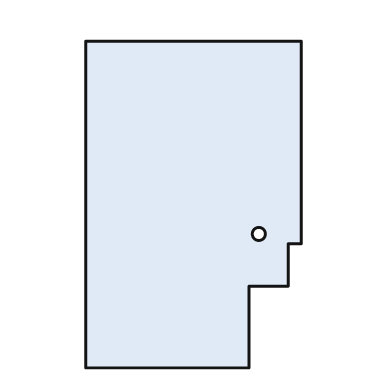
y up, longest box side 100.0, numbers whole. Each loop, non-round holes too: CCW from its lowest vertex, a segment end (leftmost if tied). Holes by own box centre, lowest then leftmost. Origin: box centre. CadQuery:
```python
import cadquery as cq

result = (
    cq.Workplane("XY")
    .moveTo(-33.0, -50.0)
    .lineTo(17.0, -50.0)
    .lineTo(17.0, -25.0)
    .lineTo(29.0, -25.0)
    .lineTo(29.0, -12.0)
    .lineTo(33.0, -12.0)
    .lineTo(33.0, 50.0)
    .lineTo(-33.0, 50.0)
    .close()
    .moveTo(20.0, -9.0)
    .circle(2.0)
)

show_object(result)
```